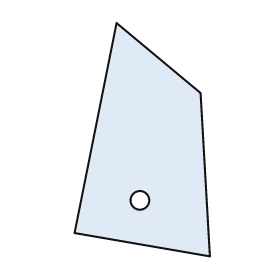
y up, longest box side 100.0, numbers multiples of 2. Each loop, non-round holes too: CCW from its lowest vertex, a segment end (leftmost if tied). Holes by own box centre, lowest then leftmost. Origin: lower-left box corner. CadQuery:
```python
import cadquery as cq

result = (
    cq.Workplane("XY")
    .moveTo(58.0, 0.0)
    .lineTo(54.0, 70.0)
    .lineTo(18.0, 100.0)
    .lineTo(0.0, 10.0)
    .close()
    .moveTo(28.0, 24.0)
    .circle(4.0)
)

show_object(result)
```